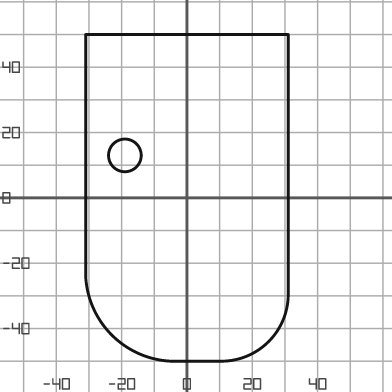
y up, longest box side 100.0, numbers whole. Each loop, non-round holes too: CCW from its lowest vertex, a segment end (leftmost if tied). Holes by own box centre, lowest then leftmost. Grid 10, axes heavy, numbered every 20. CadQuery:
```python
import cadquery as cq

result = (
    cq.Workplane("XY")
    .moveTo(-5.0, -50.0)
    .lineTo(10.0, -50.0)
    .threePointArc((25.0, -44.0), (31.0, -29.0))
    .lineTo(31.0, 50.0)
    .lineTo(-31.0, 50.0)
    .lineTo(-31.0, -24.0)
    .threePointArc((-23.0, -42.0), (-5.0, -50.0))
    .close()
    .moveTo(-19.0, 13.0)
    .circle(5.0)
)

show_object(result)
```